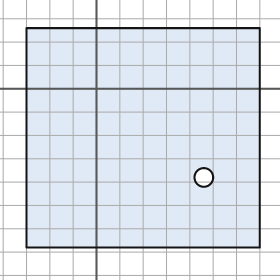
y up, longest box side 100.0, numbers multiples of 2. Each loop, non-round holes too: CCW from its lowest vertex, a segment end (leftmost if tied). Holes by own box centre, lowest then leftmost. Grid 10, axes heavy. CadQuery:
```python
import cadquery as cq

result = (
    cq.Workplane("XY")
    .moveTo(-30.0, -68.0)
    .lineTo(70.0, -68.0)
    .lineTo(70.0, 26.0)
    .lineTo(-30.0, 26.0)
    .close()
    .moveTo(46.0, -38.0)
    .circle(4.0)
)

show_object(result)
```